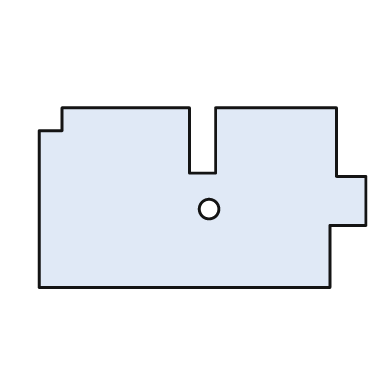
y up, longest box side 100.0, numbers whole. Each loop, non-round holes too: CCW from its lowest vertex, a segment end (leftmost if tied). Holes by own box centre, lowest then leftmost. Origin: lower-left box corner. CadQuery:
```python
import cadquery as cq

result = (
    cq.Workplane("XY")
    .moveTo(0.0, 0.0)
    .lineTo(89.0, 0.0)
    .lineTo(89.0, 19.0)
    .lineTo(100.0, 19.0)
    .lineTo(100.0, 34.0)
    .lineTo(91.0, 34.0)
    .lineTo(91.0, 55.0)
    .lineTo(54.0, 55.0)
    .lineTo(54.0, 35.0)
    .lineTo(46.0, 35.0)
    .lineTo(46.0, 55.0)
    .lineTo(7.0, 55.0)
    .lineTo(7.0, 48.0)
    .lineTo(0.0, 48.0)
    .close()
    .moveTo(52.0, 24.0)
    .circle(3.0)
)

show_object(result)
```